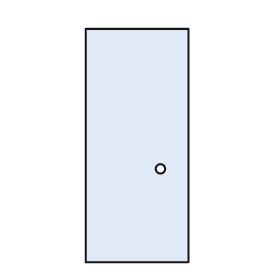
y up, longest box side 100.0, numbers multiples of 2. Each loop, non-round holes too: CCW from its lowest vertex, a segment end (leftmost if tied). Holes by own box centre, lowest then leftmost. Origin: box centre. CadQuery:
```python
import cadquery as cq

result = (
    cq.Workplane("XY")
    .moveTo(-22.0, -50.0)
    .lineTo(22.0, -50.0)
    .lineTo(22.0, 50.0)
    .lineTo(-22.0, 50.0)
    .close()
    .moveTo(10.0, -10.0)
    .circle(2.0)
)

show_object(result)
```